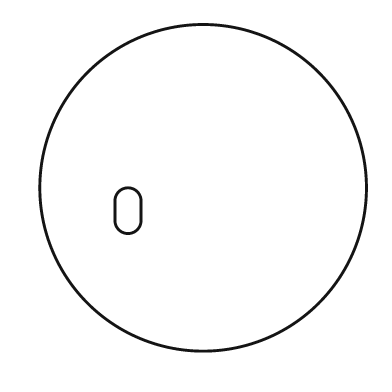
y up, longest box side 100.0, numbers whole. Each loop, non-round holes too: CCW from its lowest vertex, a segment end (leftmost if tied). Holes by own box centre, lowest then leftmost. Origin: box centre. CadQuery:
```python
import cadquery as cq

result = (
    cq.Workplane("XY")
    .moveTo(0.0, 0.0)
    .circle(50.0)
    .moveTo(-27.0, -10.0)
    .threePointArc((-23.0, -14.0), (-19.0, -10.0))
    .lineTo(-19.0, -4.0)
    .threePointArc((-23.0, 0.0), (-27.0, -4.0))
    .close()
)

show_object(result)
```